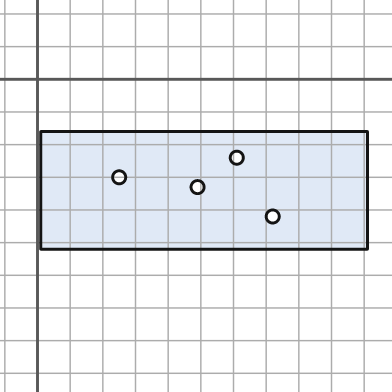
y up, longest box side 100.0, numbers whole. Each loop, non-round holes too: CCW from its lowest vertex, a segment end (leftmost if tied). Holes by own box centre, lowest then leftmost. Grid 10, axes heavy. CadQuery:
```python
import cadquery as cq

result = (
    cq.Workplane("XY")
    .moveTo(1.0, -52.0)
    .lineTo(101.0, -52.0)
    .lineTo(101.0, -16.0)
    .lineTo(1.0, -16.0)
    .close()
    .moveTo(72.0, -42.0)
    .circle(2.0)
    .moveTo(49.0, -33.0)
    .circle(2.0)
    .moveTo(25.0, -30.0)
    .circle(2.0)
    .moveTo(61.0, -24.0)
    .circle(2.0)
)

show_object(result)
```